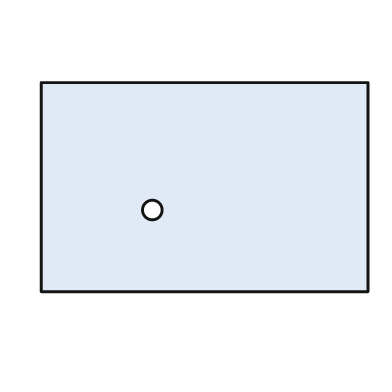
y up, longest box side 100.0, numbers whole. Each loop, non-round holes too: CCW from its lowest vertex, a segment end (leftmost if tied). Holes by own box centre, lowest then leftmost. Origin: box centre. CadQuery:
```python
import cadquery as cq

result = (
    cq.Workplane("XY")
    .moveTo(-50.0, -32.0)
    .lineTo(50.0, -32.0)
    .lineTo(50.0, 32.0)
    .lineTo(-50.0, 32.0)
    .close()
    .moveTo(-16.0, -7.0)
    .circle(3.0)
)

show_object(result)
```